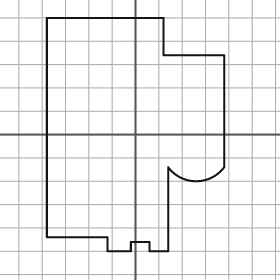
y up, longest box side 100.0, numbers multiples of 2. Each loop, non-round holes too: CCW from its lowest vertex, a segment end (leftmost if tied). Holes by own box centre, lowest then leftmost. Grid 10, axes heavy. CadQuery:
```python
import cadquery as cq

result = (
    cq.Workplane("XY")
    .moveTo(-12.0, -50.0)
    .lineTo(-2.0, -50.0)
    .lineTo(-2.0, -46.0)
    .lineTo(6.0, -46.0)
    .lineTo(6.0, -50.0)
    .lineTo(14.0, -50.0)
    .lineTo(14.0, -14.0)
    .threePointArc((26.0, -20.0), (38.0, -14.0))
    .lineTo(38.0, 34.0)
    .lineTo(12.0, 34.0)
    .lineTo(12.0, 50.0)
    .lineTo(-38.0, 50.0)
    .lineTo(-38.0, -44.0)
    .lineTo(-12.0, -44.0)
    .close()
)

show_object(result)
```